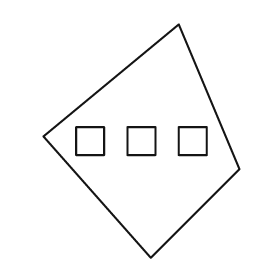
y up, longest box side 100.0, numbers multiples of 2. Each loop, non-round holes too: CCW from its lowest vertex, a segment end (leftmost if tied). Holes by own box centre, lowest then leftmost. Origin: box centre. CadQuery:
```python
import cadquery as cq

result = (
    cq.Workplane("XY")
    .moveTo(4.0, -50.0)
    .lineTo(42.0, -12.0)
    .lineTo(16.0, 50.0)
    .lineTo(-42.0, 2.0)
    .close()
    .moveTo(-28.0, -6.0)
    .lineTo(-16.0, -6.0)
    .lineTo(-16.0, 6.0)
    .lineTo(-28.0, 6.0)
    .close()
    .moveTo(-6.0, -6.0)
    .lineTo(6.0, -6.0)
    .lineTo(6.0, 6.0)
    .lineTo(-6.0, 6.0)
    .close()
    .moveTo(16.0, -6.0)
    .lineTo(28.0, -6.0)
    .lineTo(28.0, 6.0)
    .lineTo(16.0, 6.0)
    .close()
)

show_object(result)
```